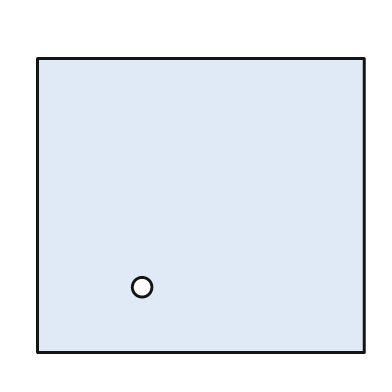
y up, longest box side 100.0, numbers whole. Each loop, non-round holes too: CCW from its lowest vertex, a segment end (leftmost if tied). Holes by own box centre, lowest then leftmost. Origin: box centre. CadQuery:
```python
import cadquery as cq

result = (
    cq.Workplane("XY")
    .moveTo(-50.0, -45.0)
    .lineTo(50.0, -45.0)
    .lineTo(50.0, 45.0)
    .lineTo(-50.0, 45.0)
    .close()
    .moveTo(-18.0, -25.0)
    .circle(3.0)
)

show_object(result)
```